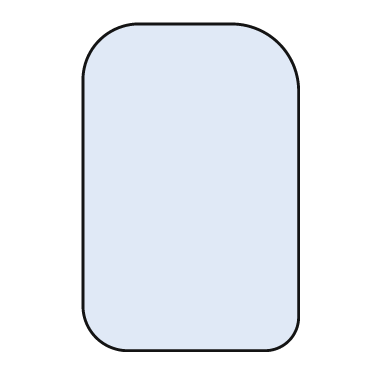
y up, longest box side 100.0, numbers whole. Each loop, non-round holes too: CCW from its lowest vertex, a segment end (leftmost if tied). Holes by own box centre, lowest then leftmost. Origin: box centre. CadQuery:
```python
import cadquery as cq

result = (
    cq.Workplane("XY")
    .moveTo(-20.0, -50.0)
    .lineTo(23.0, -50.0)
    .threePointArc((30.0, -47.0), (33.0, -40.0))
    .lineTo(33.0, 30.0)
    .threePointArc((27.0, 44.0), (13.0, 50.0))
    .lineTo(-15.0, 50.0)
    .threePointArc((-28.0, 45.0), (-33.0, 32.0))
    .lineTo(-33.0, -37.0)
    .threePointArc((-29.0, -46.0), (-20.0, -50.0))
    .close()
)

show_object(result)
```